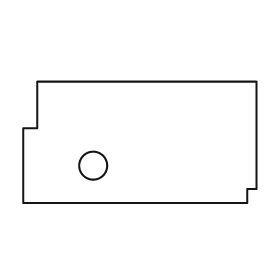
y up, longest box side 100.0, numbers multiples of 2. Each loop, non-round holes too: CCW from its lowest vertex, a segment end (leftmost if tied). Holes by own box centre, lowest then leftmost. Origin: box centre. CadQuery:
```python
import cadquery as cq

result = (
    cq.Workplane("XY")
    .moveTo(-50.0, -26.0)
    .lineTo(46.0, -26.0)
    .lineTo(46.0, -20.0)
    .lineTo(50.0, -20.0)
    .lineTo(50.0, 26.0)
    .lineTo(-44.0, 26.0)
    .lineTo(-44.0, 6.0)
    .lineTo(-50.0, 6.0)
    .close()
    .moveTo(-20.0, -10.0)
    .circle(6.0)
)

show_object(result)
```